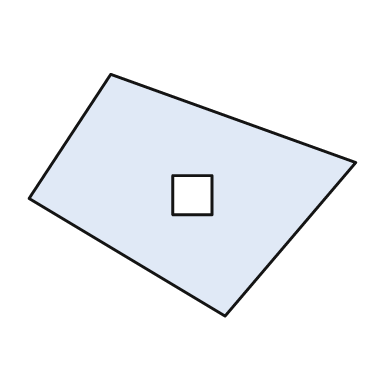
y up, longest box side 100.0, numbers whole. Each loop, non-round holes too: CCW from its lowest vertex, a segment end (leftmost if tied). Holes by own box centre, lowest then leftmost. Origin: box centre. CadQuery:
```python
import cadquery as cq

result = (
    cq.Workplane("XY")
    .moveTo(10.0, -37.0)
    .lineTo(50.0, 10.0)
    .lineTo(-25.0, 37.0)
    .lineTo(-50.0, -1.0)
    .close()
    .moveTo(-6.0, -6.0)
    .lineTo(6.0, -6.0)
    .lineTo(6.0, 6.0)
    .lineTo(-6.0, 6.0)
    .close()
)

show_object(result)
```